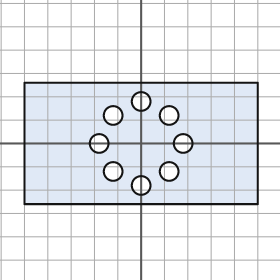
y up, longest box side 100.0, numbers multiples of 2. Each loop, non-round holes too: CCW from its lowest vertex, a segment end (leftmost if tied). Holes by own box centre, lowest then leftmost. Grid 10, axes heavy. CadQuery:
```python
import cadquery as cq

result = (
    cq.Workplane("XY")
    .moveTo(-50.0, -26.0)
    .lineTo(50.0, -26.0)
    .lineTo(50.0, 26.0)
    .lineTo(-50.0, 26.0)
    .close()
    .moveTo(0.0, -18.0)
    .circle(4.0)
    .moveTo(-12.0, -12.0)
    .circle(4.0)
    .moveTo(12.0, -12.0)
    .circle(4.0)
    .moveTo(-18.0, 0.0)
    .circle(4.0)
    .moveTo(18.0, 0.0)
    .circle(4.0)
    .moveTo(-12.0, 12.0)
    .circle(4.0)
    .moveTo(12.0, 12.0)
    .circle(4.0)
    .moveTo(0.0, 18.0)
    .circle(4.0)
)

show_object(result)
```